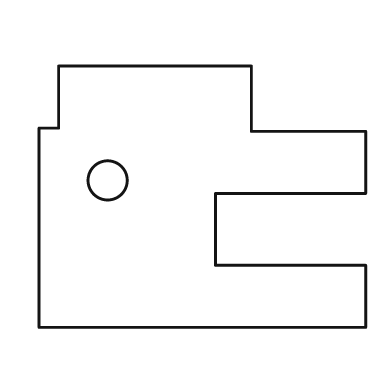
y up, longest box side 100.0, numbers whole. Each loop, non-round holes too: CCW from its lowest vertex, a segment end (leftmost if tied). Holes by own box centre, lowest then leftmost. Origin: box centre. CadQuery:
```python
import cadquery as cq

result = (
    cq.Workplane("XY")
    .moveTo(-50.0, -40.0)
    .lineTo(50.0, -40.0)
    .lineTo(50.0, -21.0)
    .lineTo(4.0, -21.0)
    .lineTo(4.0, 1.0)
    .lineTo(50.0, 1.0)
    .lineTo(50.0, 20.0)
    .lineTo(15.0, 20.0)
    .lineTo(15.0, 40.0)
    .lineTo(-44.0, 40.0)
    .lineTo(-44.0, 21.0)
    .lineTo(-50.0, 21.0)
    .close()
    .moveTo(-29.0, 5.0)
    .circle(6.0)
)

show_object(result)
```